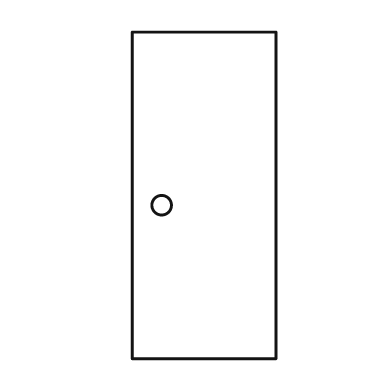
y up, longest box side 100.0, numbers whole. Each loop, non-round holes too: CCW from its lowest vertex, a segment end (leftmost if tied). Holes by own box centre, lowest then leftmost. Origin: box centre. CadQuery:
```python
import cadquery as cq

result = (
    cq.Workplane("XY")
    .moveTo(-22.0, -50.0)
    .lineTo(22.0, -50.0)
    .lineTo(22.0, 50.0)
    .lineTo(-22.0, 50.0)
    .close()
    .moveTo(-13.0, -3.0)
    .circle(3.0)
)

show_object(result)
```